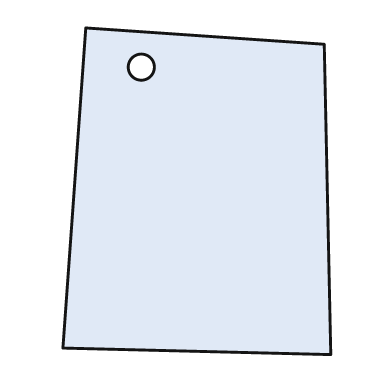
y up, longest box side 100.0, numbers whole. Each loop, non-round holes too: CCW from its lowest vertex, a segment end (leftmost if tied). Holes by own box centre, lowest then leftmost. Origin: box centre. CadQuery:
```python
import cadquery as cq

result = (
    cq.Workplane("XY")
    .moveTo(41.0, -50.0)
    .lineTo(39.0, 45.0)
    .lineTo(-34.0, 50.0)
    .lineTo(-41.0, -48.0)
    .close()
    .moveTo(-17.0, 38.0)
    .circle(4.0)
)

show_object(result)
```